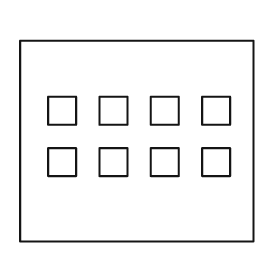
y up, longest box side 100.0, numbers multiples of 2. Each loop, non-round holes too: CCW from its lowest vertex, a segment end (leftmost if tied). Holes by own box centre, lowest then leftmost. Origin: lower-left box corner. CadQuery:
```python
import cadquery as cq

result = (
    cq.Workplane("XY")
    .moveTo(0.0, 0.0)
    .lineTo(100.0, 0.0)
    .lineTo(100.0, 86.0)
    .lineTo(0.0, 86.0)
    .close()
    .moveTo(12.0, 28.0)
    .lineTo(24.0, 28.0)
    .lineTo(24.0, 40.0)
    .lineTo(12.0, 40.0)
    .close()
    .moveTo(34.0, 28.0)
    .lineTo(46.0, 28.0)
    .lineTo(46.0, 40.0)
    .lineTo(34.0, 40.0)
    .close()
    .moveTo(56.0, 28.0)
    .lineTo(68.0, 28.0)
    .lineTo(68.0, 40.0)
    .lineTo(56.0, 40.0)
    .close()
    .moveTo(78.0, 28.0)
    .lineTo(90.0, 28.0)
    .lineTo(90.0, 40.0)
    .lineTo(78.0, 40.0)
    .close()
    .moveTo(12.0, 50.0)
    .lineTo(24.0, 50.0)
    .lineTo(24.0, 62.0)
    .lineTo(12.0, 62.0)
    .close()
    .moveTo(34.0, 50.0)
    .lineTo(46.0, 50.0)
    .lineTo(46.0, 62.0)
    .lineTo(34.0, 62.0)
    .close()
    .moveTo(56.0, 50.0)
    .lineTo(68.0, 50.0)
    .lineTo(68.0, 62.0)
    .lineTo(56.0, 62.0)
    .close()
    .moveTo(78.0, 50.0)
    .lineTo(90.0, 50.0)
    .lineTo(90.0, 62.0)
    .lineTo(78.0, 62.0)
    .close()
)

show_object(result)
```